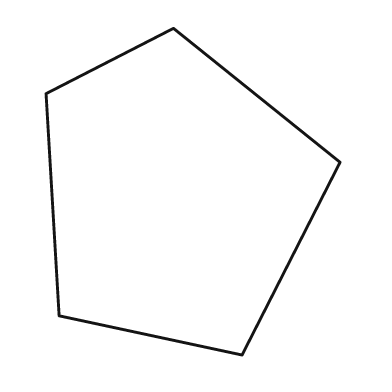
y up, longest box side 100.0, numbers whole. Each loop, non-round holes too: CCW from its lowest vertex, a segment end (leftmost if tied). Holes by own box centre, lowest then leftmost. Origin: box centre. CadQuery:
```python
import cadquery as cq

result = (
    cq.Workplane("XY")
    .moveTo(15.0, -50.0)
    .lineTo(45.0, 9.0)
    .lineTo(-6.0, 50.0)
    .lineTo(-45.0, 30.0)
    .lineTo(-41.0, -38.0)
    .close()
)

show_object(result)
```